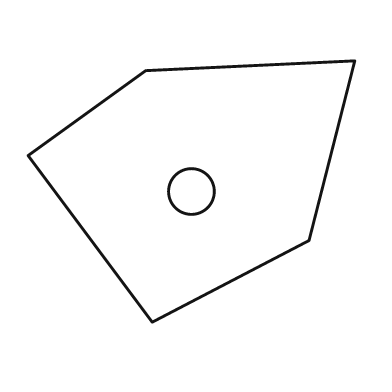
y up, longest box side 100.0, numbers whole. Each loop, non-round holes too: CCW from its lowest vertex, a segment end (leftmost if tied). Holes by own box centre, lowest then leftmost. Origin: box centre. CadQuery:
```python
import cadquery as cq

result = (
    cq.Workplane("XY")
    .moveTo(-12.0, -40.0)
    .lineTo(36.0, -15.0)
    .lineTo(50.0, 40.0)
    .lineTo(-14.0, 37.0)
    .lineTo(-50.0, 11.0)
    .close()
    .moveTo(0.0, 0.0)
    .circle(7.0)
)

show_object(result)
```